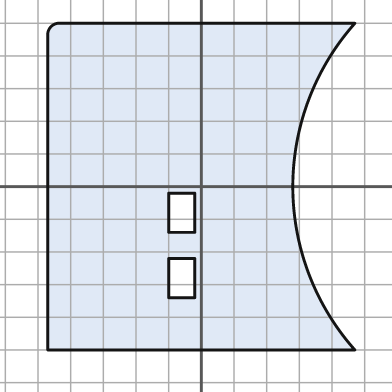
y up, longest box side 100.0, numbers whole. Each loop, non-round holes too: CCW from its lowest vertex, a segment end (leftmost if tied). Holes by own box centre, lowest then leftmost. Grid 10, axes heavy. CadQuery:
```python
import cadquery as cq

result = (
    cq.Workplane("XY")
    .moveTo(-47.0, -50.0)
    .lineTo(47.0, -50.0)
    .threePointArc((28.0, 0.0), (47.0, 50.0))
    .lineTo(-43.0, 50.0)
    .threePointArc((-46.0, 49.0), (-47.0, 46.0))
    .close()
    .moveTo(-10.0, -34.0)
    .lineTo(-2.0, -34.0)
    .lineTo(-2.0, -22.0)
    .lineTo(-10.0, -22.0)
    .close()
    .moveTo(-10.0, -14.0)
    .lineTo(-2.0, -14.0)
    .lineTo(-2.0, -2.0)
    .lineTo(-10.0, -2.0)
    .close()
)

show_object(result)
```